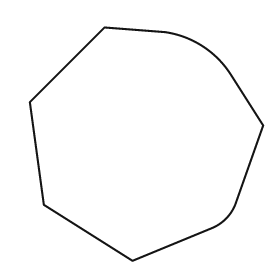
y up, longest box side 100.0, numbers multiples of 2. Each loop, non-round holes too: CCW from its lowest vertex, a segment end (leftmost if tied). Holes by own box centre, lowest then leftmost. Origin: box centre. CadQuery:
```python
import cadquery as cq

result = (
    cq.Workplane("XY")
    .moveTo(-6.0, -50.0)
    .lineTo(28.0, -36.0)
    .threePointArc((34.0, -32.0), (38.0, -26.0))
    .lineTo(50.0, 8.0)
    .lineTo(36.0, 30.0)
    .threePointArc((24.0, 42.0), (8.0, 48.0))
    .lineTo(-18.0, 50.0)
    .lineTo(-50.0, 18.0)
    .lineTo(-44.0, -26.0)
    .close()
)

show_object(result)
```